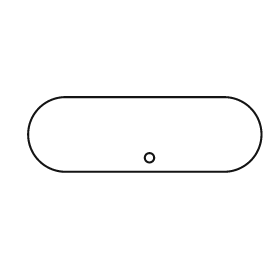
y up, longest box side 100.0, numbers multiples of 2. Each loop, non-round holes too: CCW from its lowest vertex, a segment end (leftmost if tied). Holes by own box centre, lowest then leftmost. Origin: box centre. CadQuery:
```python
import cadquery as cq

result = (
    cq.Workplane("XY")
    .moveTo(-34.0, -16.0)
    .lineTo(34.0, -16.0)
    .threePointArc((50.0, 0.0), (34.0, 16.0))
    .lineTo(-34.0, 16.0)
    .threePointArc((-50.0, 0.0), (-34.0, -16.0))
    .close()
    .moveTo(2.0, -10.0)
    .circle(2.0)
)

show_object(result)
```